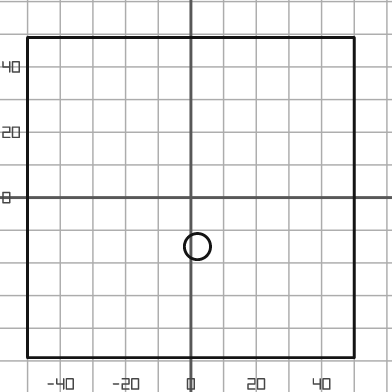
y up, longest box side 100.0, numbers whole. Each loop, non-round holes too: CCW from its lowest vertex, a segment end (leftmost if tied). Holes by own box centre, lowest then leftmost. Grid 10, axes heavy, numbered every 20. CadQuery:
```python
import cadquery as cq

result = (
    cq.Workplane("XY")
    .moveTo(-50.0, -49.0)
    .lineTo(50.0, -49.0)
    .lineTo(50.0, 49.0)
    .lineTo(-50.0, 49.0)
    .close()
    .moveTo(2.0, -15.0)
    .circle(4.0)
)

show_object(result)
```